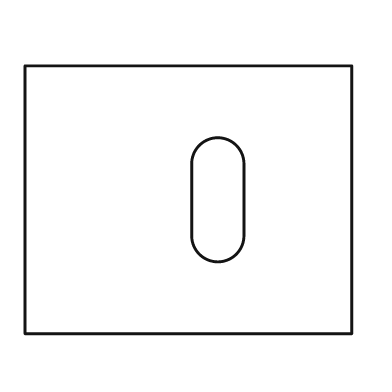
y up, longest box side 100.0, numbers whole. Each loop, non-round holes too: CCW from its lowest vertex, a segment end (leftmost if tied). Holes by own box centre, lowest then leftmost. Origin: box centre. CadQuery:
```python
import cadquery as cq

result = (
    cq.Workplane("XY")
    .moveTo(-50.0, -41.0)
    .lineTo(50.0, -41.0)
    .lineTo(50.0, 41.0)
    .lineTo(-50.0, 41.0)
    .close()
    .moveTo(1.0, -11.0)
    .threePointArc((9.0, -19.0), (17.0, -11.0))
    .lineTo(17.0, 11.0)
    .threePointArc((9.0, 19.0), (1.0, 11.0))
    .close()
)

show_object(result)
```